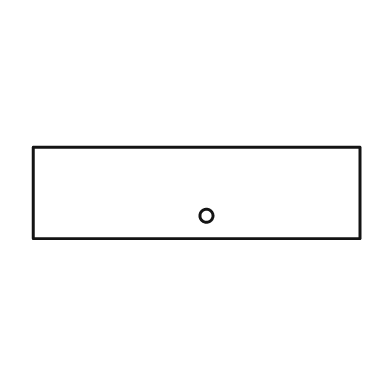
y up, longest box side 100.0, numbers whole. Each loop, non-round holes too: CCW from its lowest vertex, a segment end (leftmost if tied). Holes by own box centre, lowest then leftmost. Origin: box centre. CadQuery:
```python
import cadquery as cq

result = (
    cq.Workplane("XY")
    .moveTo(-50.0, -14.0)
    .lineTo(50.0, -14.0)
    .lineTo(50.0, 14.0)
    .lineTo(-50.0, 14.0)
    .close()
    .moveTo(3.0, -7.0)
    .circle(2.0)
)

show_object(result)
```